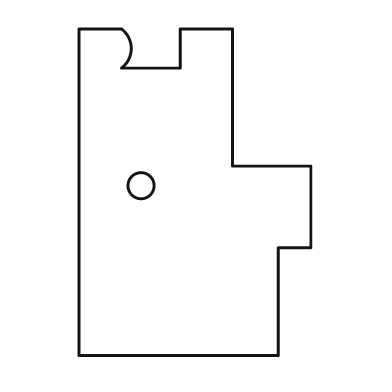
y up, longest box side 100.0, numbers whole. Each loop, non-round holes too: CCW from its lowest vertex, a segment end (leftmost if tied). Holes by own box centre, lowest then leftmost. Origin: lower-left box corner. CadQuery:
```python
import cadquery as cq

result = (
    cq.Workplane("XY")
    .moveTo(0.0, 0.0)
    .lineTo(61.0, 0.0)
    .lineTo(61.0, 33.0)
    .lineTo(71.0, 33.0)
    .lineTo(71.0, 58.0)
    .lineTo(47.0, 58.0)
    .lineTo(47.0, 100.0)
    .lineTo(31.0, 100.0)
    .lineTo(31.0, 88.0)
    .lineTo(13.0, 88.0)
    .threePointArc((16.0, 94.0), (13.0, 100.0))
    .lineTo(0.0, 100.0)
    .close()
    .moveTo(19.0, 52.0)
    .circle(4.0)
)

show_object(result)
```